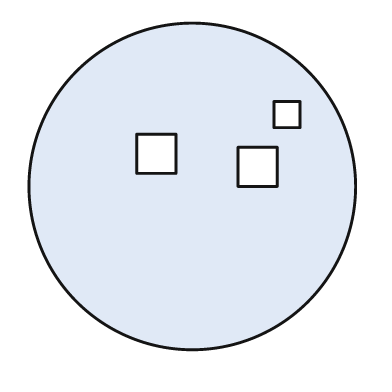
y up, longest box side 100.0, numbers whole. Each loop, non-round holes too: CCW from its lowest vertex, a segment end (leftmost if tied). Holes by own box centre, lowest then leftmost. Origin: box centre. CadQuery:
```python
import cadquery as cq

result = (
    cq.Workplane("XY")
    .moveTo(0.0, 0.0)
    .circle(50.0)
    .moveTo(14.0, 0.0)
    .lineTo(26.0, 0.0)
    .lineTo(26.0, 12.0)
    .lineTo(14.0, 12.0)
    .close()
    .moveTo(-17.0, 4.0)
    .lineTo(-5.0, 4.0)
    .lineTo(-5.0, 16.0)
    .lineTo(-17.0, 16.0)
    .close()
    .moveTo(25.0, 18.0)
    .lineTo(33.0, 18.0)
    .lineTo(33.0, 26.0)
    .lineTo(25.0, 26.0)
    .close()
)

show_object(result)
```